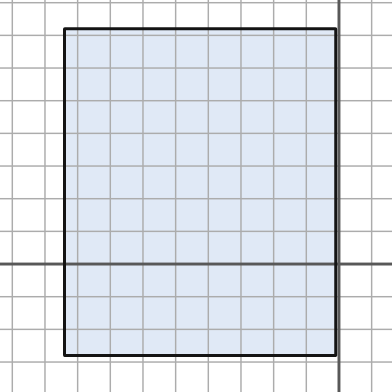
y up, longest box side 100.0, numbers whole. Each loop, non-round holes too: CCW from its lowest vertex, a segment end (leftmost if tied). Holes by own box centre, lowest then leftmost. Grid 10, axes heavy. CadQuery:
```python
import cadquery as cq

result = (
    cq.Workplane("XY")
    .moveTo(-84.0, -28.0)
    .lineTo(-1.0, -28.0)
    .lineTo(-1.0, 72.0)
    .lineTo(-84.0, 72.0)
    .close()
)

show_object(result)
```